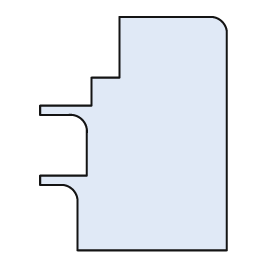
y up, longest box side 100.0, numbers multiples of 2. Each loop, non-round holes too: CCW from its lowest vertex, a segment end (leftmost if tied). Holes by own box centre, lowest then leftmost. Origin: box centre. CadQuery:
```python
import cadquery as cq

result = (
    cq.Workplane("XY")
    .moveTo(-24.0, -50.0)
    .lineTo(40.0, -50.0)
    .lineTo(40.0, 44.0)
    .threePointArc((38.0, 48.0), (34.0, 50.0))
    .lineTo(-6.0, 50.0)
    .lineTo(-6.0, 24.0)
    .lineTo(-18.0, 24.0)
    .lineTo(-18.0, 12.0)
    .lineTo(-40.0, 12.0)
    .lineTo(-40.0, 8.0)
    .lineTo(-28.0, 8.0)
    .threePointArc((-22.0, 6.0), (-20.0, 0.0))
    .lineTo(-20.0, -18.0)
    .lineTo(-40.0, -18.0)
    .lineTo(-40.0, -22.0)
    .lineTo(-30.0, -22.0)
    .threePointArc((-26.0, -24.0), (-24.0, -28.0))
    .close()
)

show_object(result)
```